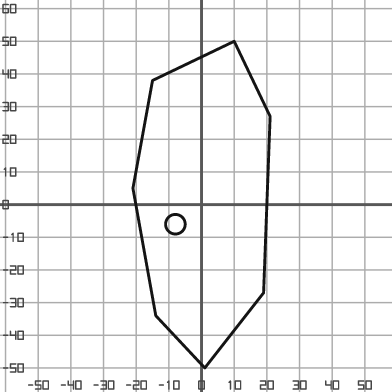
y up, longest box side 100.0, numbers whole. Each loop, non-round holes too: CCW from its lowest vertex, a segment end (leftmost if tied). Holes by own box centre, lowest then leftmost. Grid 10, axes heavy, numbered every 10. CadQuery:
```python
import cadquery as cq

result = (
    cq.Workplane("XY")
    .moveTo(1.0, -50.0)
    .lineTo(19.0, -27.0)
    .lineTo(21.0, 27.0)
    .lineTo(10.0, 50.0)
    .lineTo(-15.0, 38.0)
    .lineTo(-21.0, 5.0)
    .lineTo(-14.0, -34.0)
    .close()
    .moveTo(-8.0, -6.0)
    .circle(3.0)
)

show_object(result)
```